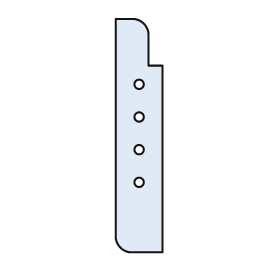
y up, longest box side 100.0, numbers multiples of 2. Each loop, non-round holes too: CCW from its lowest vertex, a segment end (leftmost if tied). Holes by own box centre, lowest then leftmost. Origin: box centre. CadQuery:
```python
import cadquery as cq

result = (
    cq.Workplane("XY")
    .moveTo(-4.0, -50.0)
    .lineTo(10.0, -50.0)
    .lineTo(10.0, 30.0)
    .lineTo(4.0, 30.0)
    .lineTo(4.0, 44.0)
    .threePointArc((2.0, 48.0), (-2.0, 50.0))
    .lineTo(-10.0, 50.0)
    .lineTo(-10.0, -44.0)
    .threePointArc((-8.0, -48.0), (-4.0, -50.0))
    .close()
    .moveTo(0.0, -20.0)
    .circle(2.0)
    .moveTo(0.0, -6.0)
    .circle(2.0)
    .moveTo(0.0, 8.0)
    .circle(2.0)
    .moveTo(0.0, 22.0)
    .circle(2.0)
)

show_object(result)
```